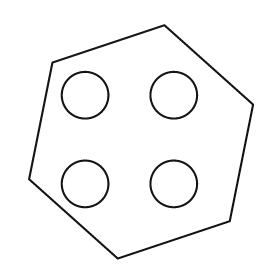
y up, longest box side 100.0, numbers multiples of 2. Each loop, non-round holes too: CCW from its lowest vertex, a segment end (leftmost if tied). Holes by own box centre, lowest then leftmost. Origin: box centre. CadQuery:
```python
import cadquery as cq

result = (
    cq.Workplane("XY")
    .moveTo(-10.0, -50.0)
    .lineTo(38.0, -34.0)
    .lineTo(48.0, 16.0)
    .lineTo(10.0, 50.0)
    .lineTo(-38.0, 34.0)
    .lineTo(-48.0, -16.0)
    .close()
    .moveTo(-24.0, -18.0)
    .circle(10.0)
    .moveTo(14.0, -18.0)
    .circle(10.0)
    .moveTo(-24.0, 20.0)
    .circle(10.0)
    .moveTo(14.0, 20.0)
    .circle(10.0)
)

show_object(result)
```